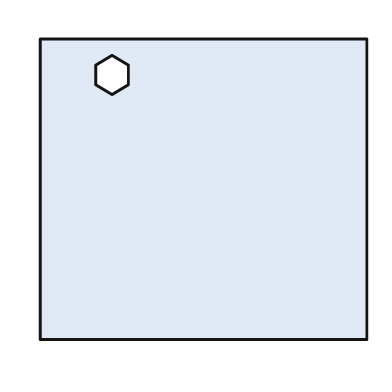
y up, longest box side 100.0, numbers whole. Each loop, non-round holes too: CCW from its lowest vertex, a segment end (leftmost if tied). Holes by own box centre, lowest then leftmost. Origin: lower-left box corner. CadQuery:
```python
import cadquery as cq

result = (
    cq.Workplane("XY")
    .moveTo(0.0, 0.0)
    .lineTo(100.0, 0.0)
    .lineTo(100.0, 92.0)
    .lineTo(0.0, 92.0)
    .close()
    .moveTo(22.0, 75.0)
    .lineTo(27.0, 78.0)
    .lineTo(27.0, 84.0)
    .lineTo(22.0, 87.0)
    .lineTo(17.0, 84.0)
    .lineTo(17.0, 78.0)
    .close()
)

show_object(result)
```